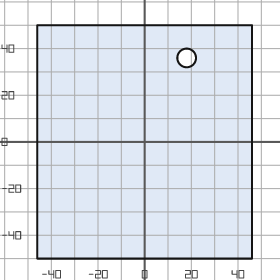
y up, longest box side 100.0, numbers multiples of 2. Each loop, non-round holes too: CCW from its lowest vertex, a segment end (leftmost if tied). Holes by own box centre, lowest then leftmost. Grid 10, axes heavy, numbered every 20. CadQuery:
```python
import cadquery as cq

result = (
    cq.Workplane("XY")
    .moveTo(-46.0, -50.0)
    .lineTo(46.0, -50.0)
    .lineTo(46.0, 50.0)
    .lineTo(-46.0, 50.0)
    .close()
    .moveTo(18.0, 36.0)
    .circle(4.0)
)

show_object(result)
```